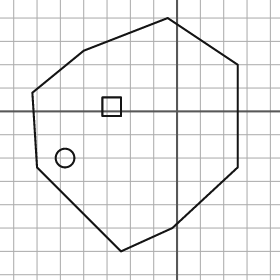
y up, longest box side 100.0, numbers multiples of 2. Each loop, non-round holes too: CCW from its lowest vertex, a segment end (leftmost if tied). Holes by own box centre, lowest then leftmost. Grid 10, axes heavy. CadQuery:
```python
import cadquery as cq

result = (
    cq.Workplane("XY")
    .moveTo(-24.0, -60.0)
    .lineTo(-2.0, -50.0)
    .lineTo(26.0, -24.0)
    .lineTo(26.0, 20.0)
    .lineTo(-4.0, 40.0)
    .lineTo(-40.0, 26.0)
    .lineTo(-62.0, 8.0)
    .lineTo(-60.0, -24.0)
    .close()
    .moveTo(-48.0, -20.0)
    .circle(4.0)
    .moveTo(-32.0, -2.0)
    .lineTo(-24.0, -2.0)
    .lineTo(-24.0, 6.0)
    .lineTo(-32.0, 6.0)
    .close()
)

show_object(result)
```